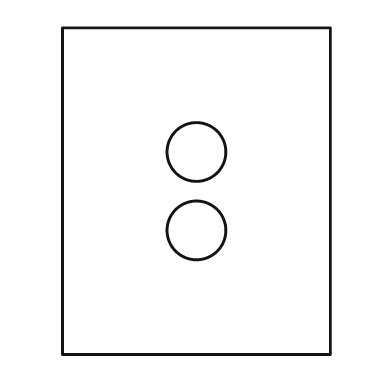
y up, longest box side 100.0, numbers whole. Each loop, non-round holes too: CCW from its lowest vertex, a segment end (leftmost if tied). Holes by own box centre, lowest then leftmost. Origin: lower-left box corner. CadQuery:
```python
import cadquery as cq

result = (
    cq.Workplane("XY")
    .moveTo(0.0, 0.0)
    .lineTo(82.0, 0.0)
    .lineTo(82.0, 100.0)
    .lineTo(0.0, 100.0)
    .close()
    .moveTo(41.0, 38.0)
    .circle(9.0)
    .moveTo(41.0, 62.0)
    .circle(9.0)
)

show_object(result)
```